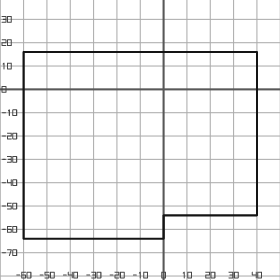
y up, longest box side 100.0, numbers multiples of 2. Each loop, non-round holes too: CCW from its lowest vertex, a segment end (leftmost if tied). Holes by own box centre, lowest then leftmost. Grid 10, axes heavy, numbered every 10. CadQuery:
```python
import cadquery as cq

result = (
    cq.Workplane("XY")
    .moveTo(-60.0, -64.0)
    .lineTo(0.0, -64.0)
    .lineTo(0.0, -54.0)
    .lineTo(40.0, -54.0)
    .lineTo(40.0, 16.0)
    .lineTo(-60.0, 16.0)
    .close()
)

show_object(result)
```